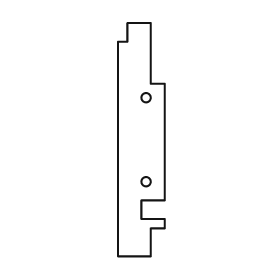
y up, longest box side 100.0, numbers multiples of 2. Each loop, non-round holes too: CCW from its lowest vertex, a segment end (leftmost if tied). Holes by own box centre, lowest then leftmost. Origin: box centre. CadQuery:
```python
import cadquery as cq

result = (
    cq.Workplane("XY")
    .moveTo(-10.0, -50.0)
    .lineTo(4.0, -50.0)
    .lineTo(4.0, -38.0)
    .lineTo(10.0, -38.0)
    .lineTo(10.0, -34.0)
    .lineTo(0.0, -34.0)
    .lineTo(0.0, -26.0)
    .lineTo(10.0, -26.0)
    .lineTo(10.0, 24.0)
    .lineTo(4.0, 24.0)
    .lineTo(4.0, 50.0)
    .lineTo(-6.0, 50.0)
    .lineTo(-6.0, 42.0)
    .lineTo(-10.0, 42.0)
    .close()
    .moveTo(2.0, -18.0)
    .circle(2.0)
    .moveTo(2.0, 18.0)
    .circle(2.0)
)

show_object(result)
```